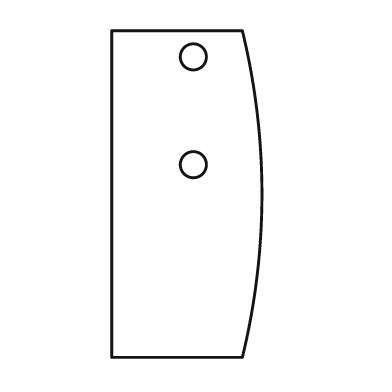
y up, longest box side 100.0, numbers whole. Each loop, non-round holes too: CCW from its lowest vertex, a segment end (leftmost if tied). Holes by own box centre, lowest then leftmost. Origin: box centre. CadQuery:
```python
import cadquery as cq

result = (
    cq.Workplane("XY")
    .moveTo(-23.0, -50.0)
    .lineTo(17.0, -50.0)
    .threePointArc((23.0, 0.0), (17.0, 50.0))
    .lineTo(-23.0, 50.0)
    .close()
    .moveTo(2.0, 9.0)
    .circle(4.0)
    .moveTo(2.0, 42.0)
    .circle(4.0)
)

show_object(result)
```